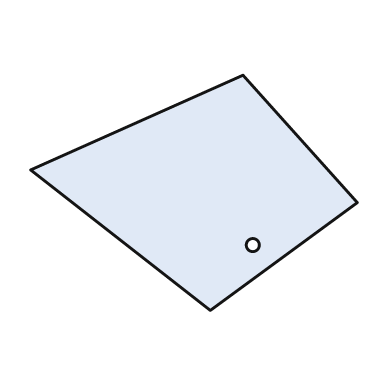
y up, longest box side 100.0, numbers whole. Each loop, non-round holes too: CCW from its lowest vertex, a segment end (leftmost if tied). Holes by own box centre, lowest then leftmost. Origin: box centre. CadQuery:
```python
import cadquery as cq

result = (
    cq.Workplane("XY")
    .moveTo(5.0, -36.0)
    .lineTo(50.0, -3.0)
    .lineTo(15.0, 36.0)
    .lineTo(-50.0, 7.0)
    .close()
    .moveTo(18.0, -16.0)
    .circle(2.0)
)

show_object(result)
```